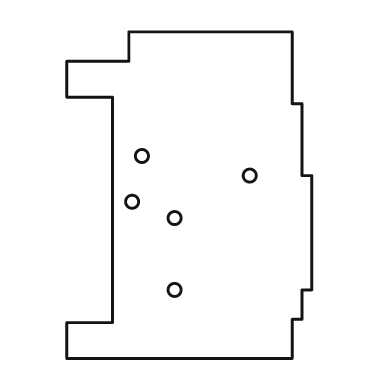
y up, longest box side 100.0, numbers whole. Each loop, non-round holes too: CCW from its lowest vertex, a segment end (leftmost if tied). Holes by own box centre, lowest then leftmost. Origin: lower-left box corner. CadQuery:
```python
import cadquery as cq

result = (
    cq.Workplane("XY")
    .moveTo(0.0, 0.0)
    .lineTo(69.0, 0.0)
    .lineTo(69.0, 12.0)
    .lineTo(72.0, 12.0)
    .lineTo(72.0, 21.0)
    .lineTo(75.0, 21.0)
    .lineTo(75.0, 56.0)
    .lineTo(72.0, 56.0)
    .lineTo(72.0, 78.0)
    .lineTo(69.0, 78.0)
    .lineTo(69.0, 100.0)
    .lineTo(19.0, 100.0)
    .lineTo(19.0, 91.0)
    .lineTo(0.0, 91.0)
    .lineTo(0.0, 80.0)
    .lineTo(14.0, 80.0)
    .lineTo(14.0, 11.0)
    .lineTo(0.0, 11.0)
    .close()
    .moveTo(33.0, 21.0)
    .circle(2.0)
    .moveTo(33.0, 43.0)
    .circle(2.0)
    .moveTo(20.0, 48.0)
    .circle(2.0)
    .moveTo(56.0, 56.0)
    .circle(2.0)
    .moveTo(23.0, 62.0)
    .circle(2.0)
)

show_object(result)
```